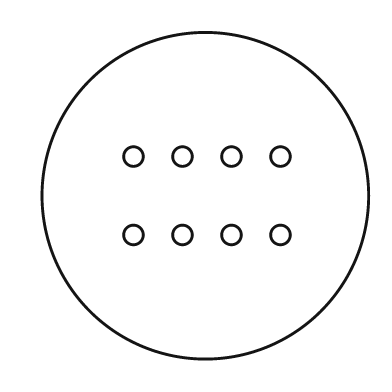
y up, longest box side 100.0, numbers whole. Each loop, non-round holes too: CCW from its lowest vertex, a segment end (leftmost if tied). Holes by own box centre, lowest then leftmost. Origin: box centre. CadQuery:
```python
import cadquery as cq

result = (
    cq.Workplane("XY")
    .moveTo(0.0, 0.0)
    .circle(50.0)
    .moveTo(-22.0, -12.0)
    .circle(3.0)
    .moveTo(-7.0, -12.0)
    .circle(3.0)
    .moveTo(8.0, -12.0)
    .circle(3.0)
    .moveTo(23.0, -12.0)
    .circle(3.0)
    .moveTo(-22.0, 12.0)
    .circle(3.0)
    .moveTo(-7.0, 12.0)
    .circle(3.0)
    .moveTo(8.0, 12.0)
    .circle(3.0)
    .moveTo(23.0, 12.0)
    .circle(3.0)
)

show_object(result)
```